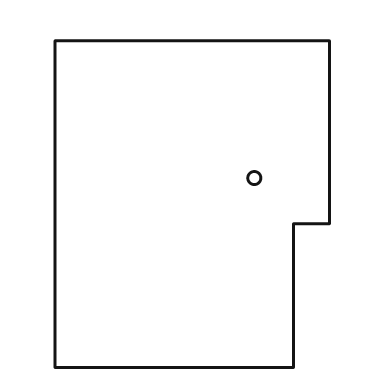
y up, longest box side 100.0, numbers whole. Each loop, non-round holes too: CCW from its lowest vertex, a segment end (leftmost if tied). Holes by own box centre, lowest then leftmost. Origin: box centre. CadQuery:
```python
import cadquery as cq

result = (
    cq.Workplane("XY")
    .moveTo(-42.0, -50.0)
    .lineTo(31.0, -50.0)
    .lineTo(31.0, -6.0)
    .lineTo(42.0, -6.0)
    .lineTo(42.0, 50.0)
    .lineTo(-42.0, 50.0)
    .close()
    .moveTo(19.0, 8.0)
    .circle(2.0)
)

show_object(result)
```